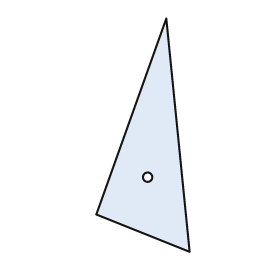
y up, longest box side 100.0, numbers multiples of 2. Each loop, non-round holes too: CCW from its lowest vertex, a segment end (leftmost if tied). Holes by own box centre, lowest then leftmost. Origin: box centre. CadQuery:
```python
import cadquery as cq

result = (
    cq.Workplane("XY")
    .moveTo(20.0, -50.0)
    .lineTo(10.0, 50.0)
    .lineTo(-20.0, -34.0)
    .close()
    .moveTo(2.0, -18.0)
    .circle(2.0)
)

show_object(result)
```